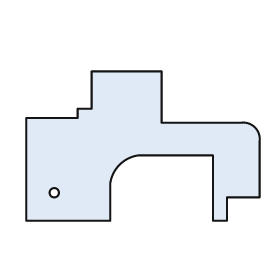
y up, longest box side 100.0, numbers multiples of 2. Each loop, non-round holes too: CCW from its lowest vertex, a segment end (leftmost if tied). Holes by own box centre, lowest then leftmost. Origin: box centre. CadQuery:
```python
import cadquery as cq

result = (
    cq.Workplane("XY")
    .moveTo(-50.0, -32.0)
    .lineTo(-14.0, -32.0)
    .lineTo(-14.0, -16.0)
    .threePointArc((-10.0, -8.0), (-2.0, -4.0))
    .lineTo(30.0, -4.0)
    .lineTo(30.0, -32.0)
    .lineTo(36.0, -32.0)
    .lineTo(36.0, -22.0)
    .lineTo(50.0, -22.0)
    .lineTo(50.0, 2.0)
    .threePointArc((48.0, 8.0), (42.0, 10.0))
    .lineTo(8.0, 10.0)
    .lineTo(8.0, 32.0)
    .lineTo(-22.0, 32.0)
    .lineTo(-22.0, 16.0)
    .lineTo(-28.0, 16.0)
    .lineTo(-28.0, 12.0)
    .lineTo(-50.0, 12.0)
    .close()
    .moveTo(-38.0, -20.0)
    .circle(2.0)
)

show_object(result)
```